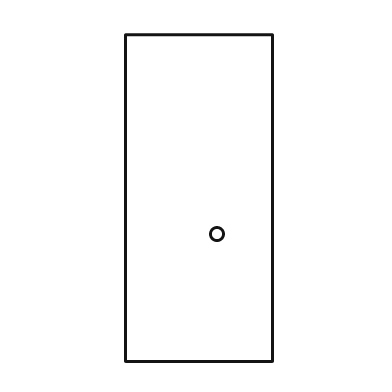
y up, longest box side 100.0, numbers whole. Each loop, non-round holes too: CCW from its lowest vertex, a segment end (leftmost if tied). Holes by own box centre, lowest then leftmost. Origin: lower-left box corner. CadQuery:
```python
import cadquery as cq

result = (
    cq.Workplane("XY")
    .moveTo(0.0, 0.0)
    .lineTo(45.0, 0.0)
    .lineTo(45.0, 100.0)
    .lineTo(0.0, 100.0)
    .close()
    .moveTo(28.0, 39.0)
    .circle(2.0)
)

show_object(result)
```